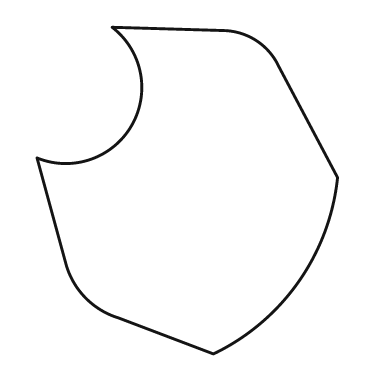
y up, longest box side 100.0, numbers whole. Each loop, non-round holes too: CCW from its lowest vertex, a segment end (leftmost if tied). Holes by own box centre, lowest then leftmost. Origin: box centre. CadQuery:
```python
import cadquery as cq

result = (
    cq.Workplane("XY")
    .moveTo(8.0, -50.0)
    .threePointArc((34.0, -28.0), (46.0, 4.0))
    .lineTo(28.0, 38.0)
    .threePointArc((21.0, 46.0), (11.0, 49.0))
    .lineTo(-23.0, 50.0)
    .threePointArc((-17.0, 20.0), (-46.0, 10.0))
    .lineTo(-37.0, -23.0)
    .threePointArc((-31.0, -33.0), (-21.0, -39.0))
    .close()
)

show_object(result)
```